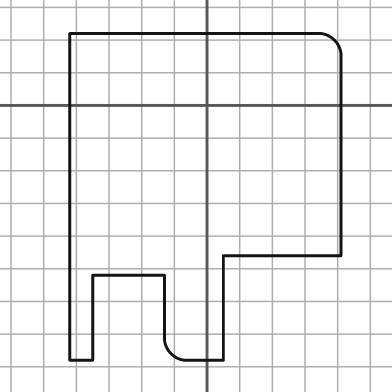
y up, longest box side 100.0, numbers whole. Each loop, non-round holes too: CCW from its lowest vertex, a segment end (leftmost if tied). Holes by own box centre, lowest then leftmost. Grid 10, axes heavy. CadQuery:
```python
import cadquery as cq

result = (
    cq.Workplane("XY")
    .moveTo(-42.0, -78.0)
    .lineTo(-35.0, -78.0)
    .lineTo(-35.0, -52.0)
    .lineTo(-13.0, -52.0)
    .lineTo(-13.0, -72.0)
    .threePointArc((-11.0, -76.0), (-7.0, -78.0))
    .lineTo(5.0, -78.0)
    .lineTo(5.0, -46.0)
    .lineTo(41.0, -46.0)
    .lineTo(41.0, 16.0)
    .threePointArc((39.0, 20.0), (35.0, 22.0))
    .lineTo(-42.0, 22.0)
    .close()
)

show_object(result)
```